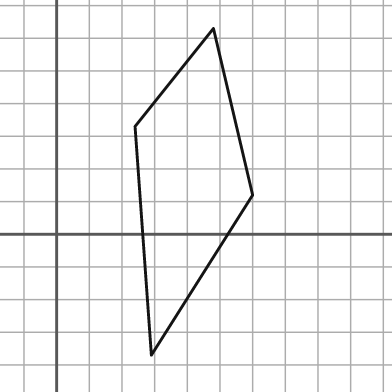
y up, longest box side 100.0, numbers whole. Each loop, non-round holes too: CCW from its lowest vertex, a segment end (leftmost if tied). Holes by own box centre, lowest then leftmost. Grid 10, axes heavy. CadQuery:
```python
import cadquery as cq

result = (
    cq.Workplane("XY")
    .moveTo(29.0, -37.0)
    .lineTo(60.0, 12.0)
    .lineTo(48.0, 63.0)
    .lineTo(24.0, 33.0)
    .close()
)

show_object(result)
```